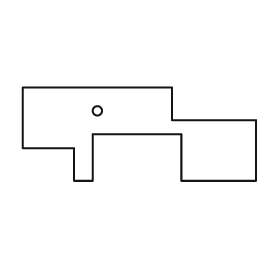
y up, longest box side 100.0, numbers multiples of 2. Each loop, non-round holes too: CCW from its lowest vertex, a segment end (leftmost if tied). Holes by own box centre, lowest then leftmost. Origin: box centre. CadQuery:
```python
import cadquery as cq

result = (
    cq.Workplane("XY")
    .moveTo(-28.0, -20.0)
    .lineTo(-20.0, -20.0)
    .lineTo(-20.0, 0.0)
    .lineTo(18.0, 0.0)
    .lineTo(18.0, -20.0)
    .lineTo(50.0, -20.0)
    .lineTo(50.0, 6.0)
    .lineTo(14.0, 6.0)
    .lineTo(14.0, 20.0)
    .lineTo(-50.0, 20.0)
    .lineTo(-50.0, -6.0)
    .lineTo(-28.0, -6.0)
    .close()
    .moveTo(-18.0, 10.0)
    .circle(2.0)
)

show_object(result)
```